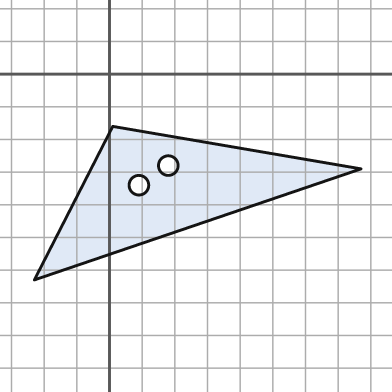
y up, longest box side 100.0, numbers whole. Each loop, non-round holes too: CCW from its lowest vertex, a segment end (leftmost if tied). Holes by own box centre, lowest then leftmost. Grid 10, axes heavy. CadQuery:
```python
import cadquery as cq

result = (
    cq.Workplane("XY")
    .moveTo(-23.0, -63.0)
    .lineTo(77.0, -29.0)
    .lineTo(1.0, -16.0)
    .close()
    .moveTo(9.0, -34.0)
    .circle(3.0)
    .moveTo(18.0, -28.0)
    .circle(3.0)
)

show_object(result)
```